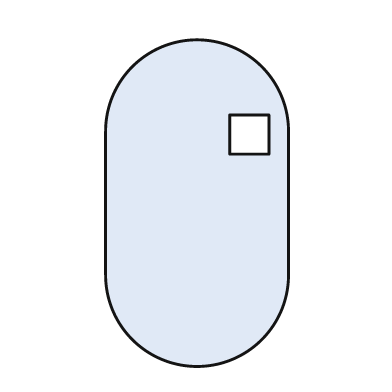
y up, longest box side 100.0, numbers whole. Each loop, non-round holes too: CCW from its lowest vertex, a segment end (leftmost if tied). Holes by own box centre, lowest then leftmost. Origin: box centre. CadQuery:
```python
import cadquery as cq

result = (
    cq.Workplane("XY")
    .moveTo(-28.0, -22.0)
    .threePointArc((0.0, -50.0), (28.0, -22.0))
    .lineTo(28.0, 22.0)
    .threePointArc((0.0, 50.0), (-28.0, 22.0))
    .close()
    .moveTo(10.0, 15.0)
    .lineTo(22.0, 15.0)
    .lineTo(22.0, 27.0)
    .lineTo(10.0, 27.0)
    .close()
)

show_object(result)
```